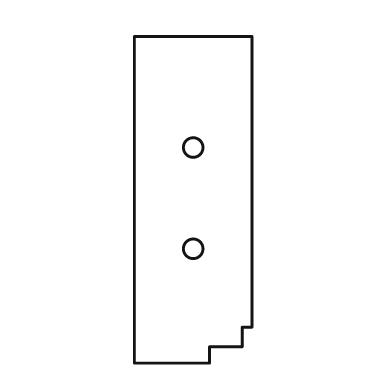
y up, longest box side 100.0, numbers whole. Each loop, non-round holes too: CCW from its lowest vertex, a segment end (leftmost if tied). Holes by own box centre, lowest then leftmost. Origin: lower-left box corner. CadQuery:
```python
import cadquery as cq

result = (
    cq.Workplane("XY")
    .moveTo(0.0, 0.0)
    .lineTo(23.0, 0.0)
    .lineTo(23.0, 5.0)
    .lineTo(33.0, 5.0)
    .lineTo(33.0, 11.0)
    .lineTo(36.0, 11.0)
    .lineTo(36.0, 100.0)
    .lineTo(0.0, 100.0)
    .close()
    .moveTo(18.0, 35.0)
    .circle(3.0)
    .moveTo(18.0, 66.0)
    .circle(3.0)
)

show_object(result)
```